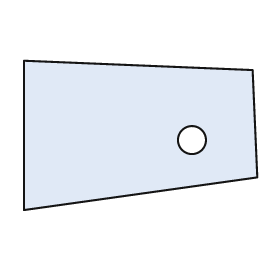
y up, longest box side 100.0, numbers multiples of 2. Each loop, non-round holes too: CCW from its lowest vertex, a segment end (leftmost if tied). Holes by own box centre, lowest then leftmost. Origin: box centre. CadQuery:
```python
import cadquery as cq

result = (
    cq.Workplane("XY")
    .moveTo(-50.0, -32.0)
    .lineTo(50.0, -18.0)
    .lineTo(48.0, 28.0)
    .lineTo(-50.0, 32.0)
    .close()
    .moveTo(22.0, -2.0)
    .circle(6.0)
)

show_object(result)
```